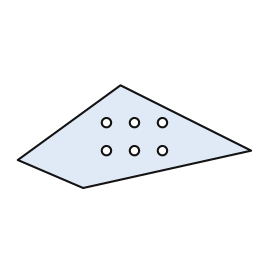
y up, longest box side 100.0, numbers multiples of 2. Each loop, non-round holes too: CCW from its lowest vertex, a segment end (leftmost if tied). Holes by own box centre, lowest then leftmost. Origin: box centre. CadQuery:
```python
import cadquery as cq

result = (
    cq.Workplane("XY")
    .moveTo(-22.0, -22.0)
    .lineTo(50.0, -6.0)
    .lineTo(-6.0, 22.0)
    .lineTo(-50.0, -10.0)
    .close()
    .moveTo(-12.0, -6.0)
    .circle(2.0)
    .moveTo(0.0, -6.0)
    .circle(2.0)
    .moveTo(12.0, -6.0)
    .circle(2.0)
    .moveTo(-12.0, 6.0)
    .circle(2.0)
    .moveTo(0.0, 6.0)
    .circle(2.0)
    .moveTo(12.0, 6.0)
    .circle(2.0)
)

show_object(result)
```